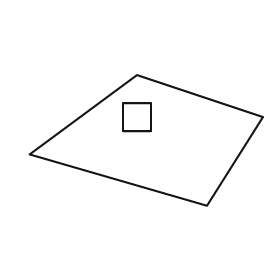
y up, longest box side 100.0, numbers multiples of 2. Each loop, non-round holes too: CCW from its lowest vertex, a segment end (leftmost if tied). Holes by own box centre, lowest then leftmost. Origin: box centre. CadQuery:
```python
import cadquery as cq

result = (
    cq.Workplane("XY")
    .moveTo(26.0, -28.0)
    .lineTo(50.0, 10.0)
    .lineTo(-4.0, 28.0)
    .lineTo(-50.0, -6.0)
    .close()
    .moveTo(-10.0, 4.0)
    .lineTo(2.0, 4.0)
    .lineTo(2.0, 16.0)
    .lineTo(-10.0, 16.0)
    .close()
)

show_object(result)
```